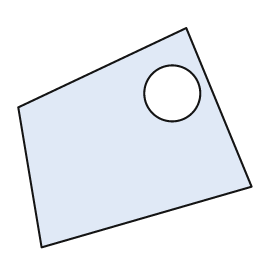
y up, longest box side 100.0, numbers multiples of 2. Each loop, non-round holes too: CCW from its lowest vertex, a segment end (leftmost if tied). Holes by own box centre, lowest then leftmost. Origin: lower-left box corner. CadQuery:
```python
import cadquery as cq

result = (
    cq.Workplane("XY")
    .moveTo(10.0, 0.0)
    .lineTo(100.0, 26.0)
    .lineTo(72.0, 94.0)
    .lineTo(0.0, 60.0)
    .close()
    .moveTo(66.0, 66.0)
    .circle(12.0)
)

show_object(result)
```